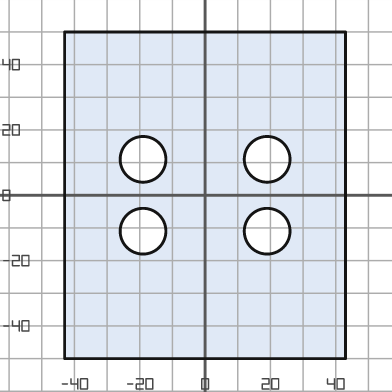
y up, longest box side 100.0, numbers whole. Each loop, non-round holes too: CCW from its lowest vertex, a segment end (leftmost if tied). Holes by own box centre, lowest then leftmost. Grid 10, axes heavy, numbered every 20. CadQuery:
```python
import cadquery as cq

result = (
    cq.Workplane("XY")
    .moveTo(-43.0, -50.0)
    .lineTo(43.0, -50.0)
    .lineTo(43.0, 50.0)
    .lineTo(-43.0, 50.0)
    .close()
    .moveTo(-19.0, -11.0)
    .circle(7.0)
    .moveTo(19.0, -11.0)
    .circle(7.0)
    .moveTo(-19.0, 11.0)
    .circle(7.0)
    .moveTo(19.0, 11.0)
    .circle(7.0)
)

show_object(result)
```